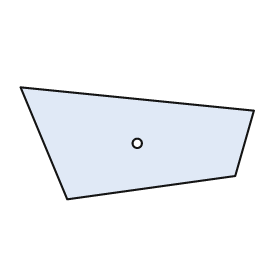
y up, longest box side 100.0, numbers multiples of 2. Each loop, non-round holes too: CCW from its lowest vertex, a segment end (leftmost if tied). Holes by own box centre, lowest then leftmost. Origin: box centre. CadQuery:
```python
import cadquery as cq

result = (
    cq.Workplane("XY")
    .moveTo(-30.0, -24.0)
    .lineTo(42.0, -14.0)
    .lineTo(50.0, 14.0)
    .lineTo(-50.0, 24.0)
    .close()
    .moveTo(0.0, 0.0)
    .circle(2.0)
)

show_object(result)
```